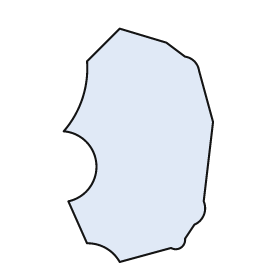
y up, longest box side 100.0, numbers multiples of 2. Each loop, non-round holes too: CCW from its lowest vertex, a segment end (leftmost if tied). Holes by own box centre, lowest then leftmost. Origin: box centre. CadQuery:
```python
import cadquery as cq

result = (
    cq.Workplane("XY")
    .moveTo(-8.0, -50.0)
    .lineTo(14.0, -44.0)
    .threePointArc((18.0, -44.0), (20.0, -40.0))
    .lineTo(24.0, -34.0)
    .threePointArc((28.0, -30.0), (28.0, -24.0))
    .lineTo(32.0, 10.0)
    .lineTo(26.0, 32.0)
    .threePointArc((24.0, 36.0), (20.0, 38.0))
    .lineTo(12.0, 44.0)
    .lineTo(-8.0, 50.0)
    .lineTo(-22.0, 36.0)
    .threePointArc((-24.0, 20.0), (-32.0, 6.0))
    .threePointArc((-18.0, -8.0), (-30.0, -24.0))
    .lineTo(-22.0, -42.0)
    .threePointArc((-14.0, -44.0), (-8.0, -50.0))
    .close()
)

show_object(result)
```